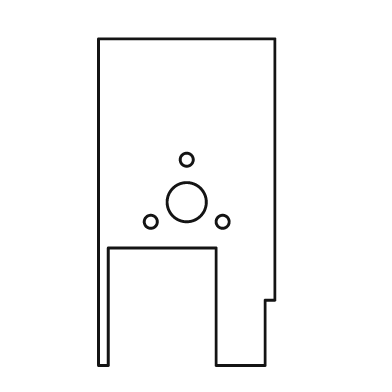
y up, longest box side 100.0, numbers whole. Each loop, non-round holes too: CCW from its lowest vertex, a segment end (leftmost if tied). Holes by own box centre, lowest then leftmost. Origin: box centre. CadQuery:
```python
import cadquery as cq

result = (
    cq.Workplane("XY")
    .moveTo(-27.0, -50.0)
    .lineTo(-24.0, -50.0)
    .lineTo(-24.0, -14.0)
    .lineTo(9.0, -14.0)
    .lineTo(9.0, -50.0)
    .lineTo(24.0, -50.0)
    .lineTo(24.0, -30.0)
    .lineTo(27.0, -30.0)
    .lineTo(27.0, 50.0)
    .lineTo(-27.0, 50.0)
    .close()
    .moveTo(-11.0, -6.0)
    .circle(2.0)
    .moveTo(11.0, -6.0)
    .circle(2.0)
    .moveTo(0.0, 0.0)
    .circle(6.0)
    .moveTo(0.0, 13.0)
    .circle(2.0)
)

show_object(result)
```